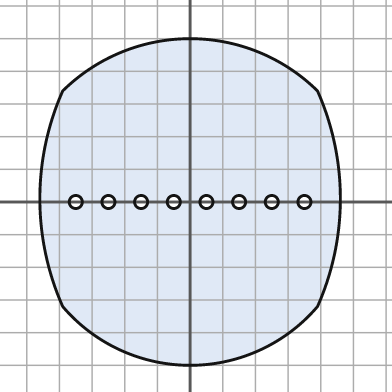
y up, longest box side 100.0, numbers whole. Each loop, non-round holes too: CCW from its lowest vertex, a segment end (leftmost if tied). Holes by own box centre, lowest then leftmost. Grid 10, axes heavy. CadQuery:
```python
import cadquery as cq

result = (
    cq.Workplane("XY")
    .moveTo(-39.0, -32.0)
    .threePointArc((0.0, -50.0), (39.0, -32.0))
    .threePointArc((46.0, 1.0), (39.0, 34.0))
    .threePointArc((0.0, 50.0), (-39.0, 34.0))
    .threePointArc((-46.0, 1.0), (-39.0, -32.0))
    .close()
    .moveTo(-35.0, 0.0)
    .circle(2.0)
    .moveTo(-25.0, 0.0)
    .circle(2.0)
    .moveTo(-15.0, 0.0)
    .circle(2.0)
    .moveTo(-5.0, 0.0)
    .circle(2.0)
    .moveTo(5.0, 0.0)
    .circle(2.0)
    .moveTo(15.0, 0.0)
    .circle(2.0)
    .moveTo(25.0, 0.0)
    .circle(2.0)
    .moveTo(35.0, 0.0)
    .circle(2.0)
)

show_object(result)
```